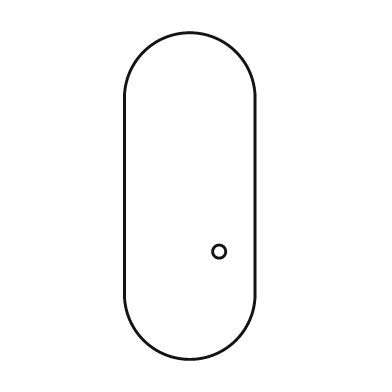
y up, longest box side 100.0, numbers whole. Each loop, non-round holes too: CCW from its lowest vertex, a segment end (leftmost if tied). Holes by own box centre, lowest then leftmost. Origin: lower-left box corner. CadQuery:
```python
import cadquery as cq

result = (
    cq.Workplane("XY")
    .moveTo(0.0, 20.0)
    .threePointArc((20.0, 0.0), (40.0, 20.0))
    .lineTo(40.0, 80.0)
    .threePointArc((20.0, 100.0), (0.0, 80.0))
    .close()
    .moveTo(29.0, 33.0)
    .circle(2.0)
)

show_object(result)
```